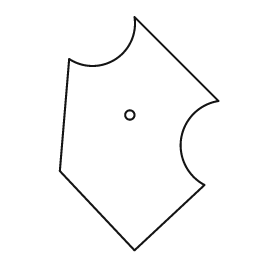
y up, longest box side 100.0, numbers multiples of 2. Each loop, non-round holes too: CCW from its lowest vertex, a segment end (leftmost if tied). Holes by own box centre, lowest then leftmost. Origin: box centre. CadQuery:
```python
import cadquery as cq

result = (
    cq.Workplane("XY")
    .moveTo(-2.0, -50.0)
    .lineTo(28.0, -22.0)
    .threePointArc((18.0, -2.0), (34.0, 14.0))
    .lineTo(-2.0, 50.0)
    .threePointArc((-10.0, 32.0), (-30.0, 32.0))
    .lineTo(-34.0, -16.0)
    .close()
    .moveTo(-4.0, 8.0)
    .circle(2.0)
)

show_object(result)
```